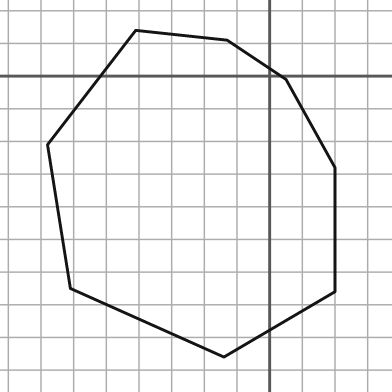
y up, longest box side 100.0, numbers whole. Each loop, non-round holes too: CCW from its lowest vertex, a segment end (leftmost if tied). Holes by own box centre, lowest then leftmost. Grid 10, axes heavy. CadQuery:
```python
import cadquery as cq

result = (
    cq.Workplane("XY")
    .moveTo(-14.0, -86.0)
    .lineTo(20.0, -66.0)
    .lineTo(20.0, -28.0)
    .lineTo(5.0, -1.0)
    .lineTo(-13.0, 11.0)
    .lineTo(-41.0, 14.0)
    .lineTo(-68.0, -21.0)
    .lineTo(-61.0, -65.0)
    .close()
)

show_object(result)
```